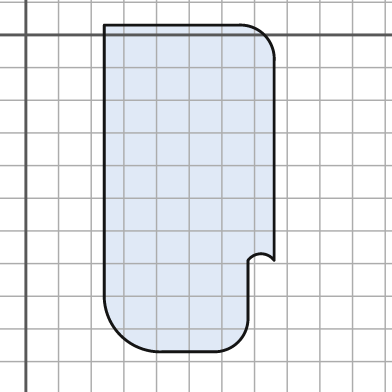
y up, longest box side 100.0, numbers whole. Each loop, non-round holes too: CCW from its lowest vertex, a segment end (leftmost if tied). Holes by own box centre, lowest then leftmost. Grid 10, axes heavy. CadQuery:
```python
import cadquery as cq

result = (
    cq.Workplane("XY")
    .moveTo(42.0, -97.0)
    .lineTo(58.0, -97.0)
    .threePointArc((65.0, -94.0), (68.0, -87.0))
    .lineTo(68.0, -69.0)
    .threePointArc((72.0, -67.0), (76.0, -69.0))
    .lineTo(76.0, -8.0)
    .threePointArc((73.0, 0.0), (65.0, 3.0))
    .lineTo(24.0, 3.0)
    .lineTo(24.0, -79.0)
    .threePointArc((29.0, -92.0), (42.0, -97.0))
    .close()
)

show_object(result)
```